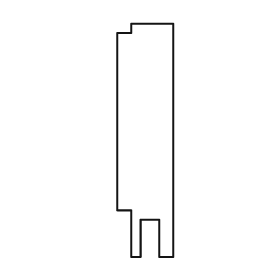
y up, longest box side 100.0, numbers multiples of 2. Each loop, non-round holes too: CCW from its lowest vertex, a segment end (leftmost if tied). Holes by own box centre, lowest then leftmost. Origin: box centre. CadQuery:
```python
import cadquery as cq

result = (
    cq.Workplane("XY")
    .moveTo(-6.0, -50.0)
    .lineTo(-2.0, -50.0)
    .lineTo(-2.0, -34.0)
    .lineTo(6.0, -34.0)
    .lineTo(6.0, -50.0)
    .lineTo(12.0, -50.0)
    .lineTo(12.0, 50.0)
    .lineTo(-6.0, 50.0)
    .lineTo(-6.0, 46.0)
    .lineTo(-12.0, 46.0)
    .lineTo(-12.0, -30.0)
    .lineTo(-6.0, -30.0)
    .close()
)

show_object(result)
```